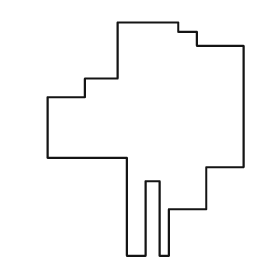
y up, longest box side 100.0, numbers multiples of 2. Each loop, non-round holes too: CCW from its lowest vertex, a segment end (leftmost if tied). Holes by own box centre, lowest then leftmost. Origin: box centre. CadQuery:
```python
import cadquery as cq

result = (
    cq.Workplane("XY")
    .moveTo(-8.0, -50.0)
    .lineTo(0.0, -50.0)
    .lineTo(0.0, -18.0)
    .lineTo(6.0, -18.0)
    .lineTo(6.0, -50.0)
    .lineTo(10.0, -50.0)
    .lineTo(10.0, -30.0)
    .lineTo(26.0, -30.0)
    .lineTo(26.0, -12.0)
    .lineTo(42.0, -12.0)
    .lineTo(42.0, 40.0)
    .lineTo(22.0, 40.0)
    .lineTo(22.0, 46.0)
    .lineTo(14.0, 46.0)
    .lineTo(14.0, 50.0)
    .lineTo(-12.0, 50.0)
    .lineTo(-12.0, 26.0)
    .lineTo(-26.0, 26.0)
    .lineTo(-26.0, 18.0)
    .lineTo(-42.0, 18.0)
    .lineTo(-42.0, -8.0)
    .lineTo(-8.0, -8.0)
    .close()
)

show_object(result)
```